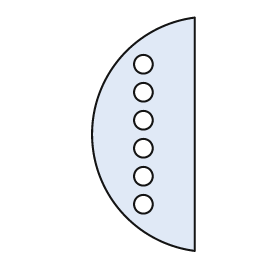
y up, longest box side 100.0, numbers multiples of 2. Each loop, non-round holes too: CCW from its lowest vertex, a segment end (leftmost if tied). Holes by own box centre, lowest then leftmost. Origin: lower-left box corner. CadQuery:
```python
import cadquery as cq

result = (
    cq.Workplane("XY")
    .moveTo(44.0, 0.0)
    .lineTo(44.0, 100.0)
    .threePointArc((0.0, 50.0), (44.0, 0.0))
    .close()
    .moveTo(22.0, 20.0)
    .circle(4.0)
    .moveTo(22.0, 32.0)
    .circle(4.0)
    .moveTo(22.0, 44.0)
    .circle(4.0)
    .moveTo(22.0, 56.0)
    .circle(4.0)
    .moveTo(22.0, 68.0)
    .circle(4.0)
    .moveTo(22.0, 80.0)
    .circle(4.0)
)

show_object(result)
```